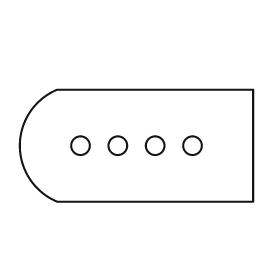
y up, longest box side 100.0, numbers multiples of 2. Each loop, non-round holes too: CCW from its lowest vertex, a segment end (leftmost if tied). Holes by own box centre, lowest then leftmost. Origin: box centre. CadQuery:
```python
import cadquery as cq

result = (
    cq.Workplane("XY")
    .moveTo(-34.0, -24.0)
    .lineTo(50.0, -24.0)
    .lineTo(50.0, 24.0)
    .lineTo(-34.0, 24.0)
    .threePointArc((-50.0, 0.0), (-34.0, -24.0))
    .close()
    .moveTo(-24.0, 0.0)
    .circle(4.0)
    .moveTo(-8.0, 0.0)
    .circle(4.0)
    .moveTo(8.0, 0.0)
    .circle(4.0)
    .moveTo(24.0, 0.0)
    .circle(4.0)
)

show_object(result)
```